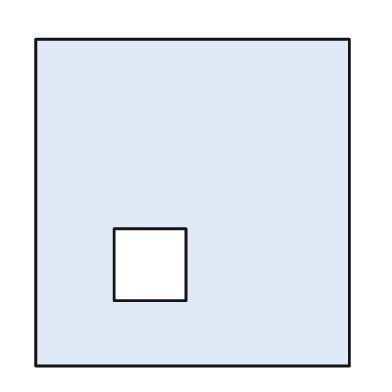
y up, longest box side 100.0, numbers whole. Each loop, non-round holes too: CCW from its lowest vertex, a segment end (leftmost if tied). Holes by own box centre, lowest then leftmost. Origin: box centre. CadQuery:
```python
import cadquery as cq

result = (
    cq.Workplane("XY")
    .moveTo(-48.0, -50.0)
    .lineTo(48.0, -50.0)
    .lineTo(48.0, 50.0)
    .lineTo(-48.0, 50.0)
    .close()
    .moveTo(-24.0, -30.0)
    .lineTo(-2.0, -30.0)
    .lineTo(-2.0, -8.0)
    .lineTo(-24.0, -8.0)
    .close()
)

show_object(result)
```